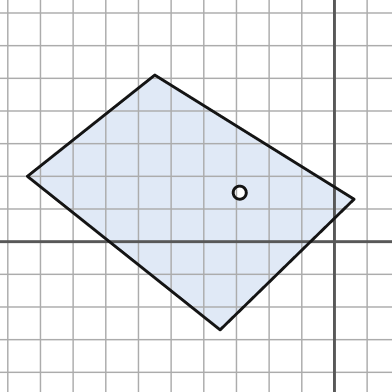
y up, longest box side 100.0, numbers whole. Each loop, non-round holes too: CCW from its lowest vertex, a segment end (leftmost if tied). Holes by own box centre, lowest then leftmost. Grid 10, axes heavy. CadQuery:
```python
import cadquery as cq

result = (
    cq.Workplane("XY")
    .moveTo(-35.0, -27.0)
    .lineTo(6.0, 13.0)
    .lineTo(-55.0, 51.0)
    .lineTo(-94.0, 20.0)
    .close()
    .moveTo(-29.0, 15.0)
    .circle(2.0)
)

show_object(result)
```